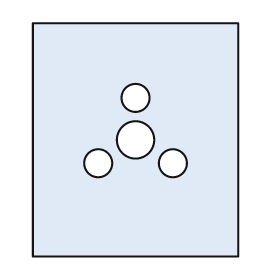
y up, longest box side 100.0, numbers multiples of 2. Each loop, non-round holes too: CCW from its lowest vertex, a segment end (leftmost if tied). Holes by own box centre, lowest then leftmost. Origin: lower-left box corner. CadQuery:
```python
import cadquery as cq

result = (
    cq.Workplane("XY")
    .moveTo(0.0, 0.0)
    .lineTo(88.0, 0.0)
    .lineTo(88.0, 100.0)
    .lineTo(0.0, 100.0)
    .close()
    .moveTo(28.0, 40.0)
    .circle(6.0)
    .moveTo(60.0, 40.0)
    .circle(6.0)
    .moveTo(44.0, 50.0)
    .circle(8.0)
    .moveTo(44.0, 68.0)
    .circle(6.0)
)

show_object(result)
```